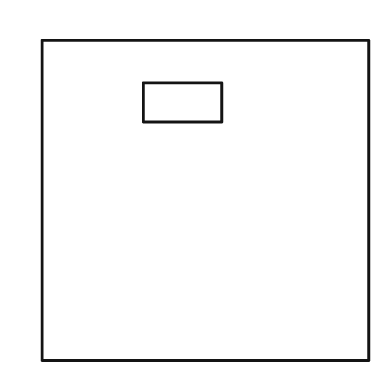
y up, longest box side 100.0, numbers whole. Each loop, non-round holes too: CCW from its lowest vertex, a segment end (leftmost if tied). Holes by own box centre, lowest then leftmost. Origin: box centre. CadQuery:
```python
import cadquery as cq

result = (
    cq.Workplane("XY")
    .moveTo(-50.0, -49.0)
    .lineTo(50.0, -49.0)
    .lineTo(50.0, 49.0)
    .lineTo(-50.0, 49.0)
    .close()
    .moveTo(-19.0, 24.0)
    .lineTo(5.0, 24.0)
    .lineTo(5.0, 36.0)
    .lineTo(-19.0, 36.0)
    .close()
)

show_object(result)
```